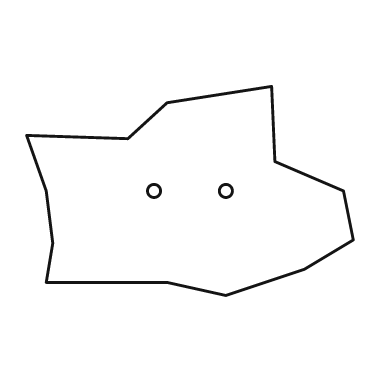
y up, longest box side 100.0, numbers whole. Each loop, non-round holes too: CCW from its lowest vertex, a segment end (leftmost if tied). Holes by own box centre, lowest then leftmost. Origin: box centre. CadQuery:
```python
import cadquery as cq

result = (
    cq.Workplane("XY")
    .moveTo(11.0, -32.0)
    .lineTo(35.0, -24.0)
    .lineTo(50.0, -15.0)
    .lineTo(47.0, 0.0)
    .lineTo(26.0, 9.0)
    .lineTo(25.0, 32.0)
    .lineTo(-7.0, 27.0)
    .lineTo(-19.0, 16.0)
    .lineTo(-50.0, 17.0)
    .lineTo(-44.0, 0.0)
    .lineTo(-42.0, -16.0)
    .lineTo(-44.0, -28.0)
    .lineTo(-7.0, -28.0)
    .close()
    .moveTo(-11.0, 0.0)
    .circle(2.0)
    .moveTo(11.0, 0.0)
    .circle(2.0)
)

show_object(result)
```